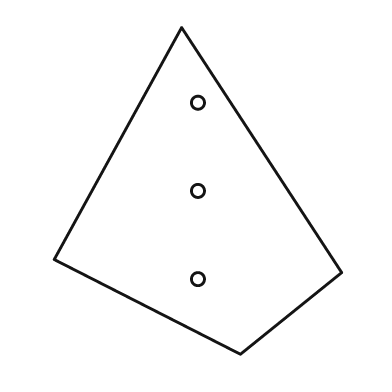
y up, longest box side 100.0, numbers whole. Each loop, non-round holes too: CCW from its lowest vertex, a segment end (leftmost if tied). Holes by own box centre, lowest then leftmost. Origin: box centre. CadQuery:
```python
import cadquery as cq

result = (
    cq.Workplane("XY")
    .moveTo(13.0, -50.0)
    .lineTo(44.0, -25.0)
    .lineTo(-5.0, 50.0)
    .lineTo(-44.0, -21.0)
    .close()
    .moveTo(0.0, -27.0)
    .circle(2.0)
    .moveTo(0.0, 0.0)
    .circle(2.0)
    .moveTo(0.0, 27.0)
    .circle(2.0)
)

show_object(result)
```